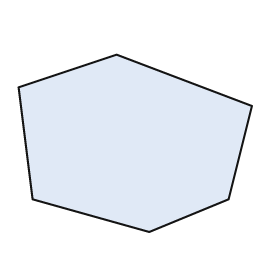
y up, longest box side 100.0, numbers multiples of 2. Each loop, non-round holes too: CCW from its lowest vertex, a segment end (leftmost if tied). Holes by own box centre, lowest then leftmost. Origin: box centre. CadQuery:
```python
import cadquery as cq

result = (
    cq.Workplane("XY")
    .moveTo(6.0, -38.0)
    .lineTo(40.0, -24.0)
    .lineTo(50.0, 16.0)
    .lineTo(-8.0, 38.0)
    .lineTo(-50.0, 24.0)
    .lineTo(-44.0, -24.0)
    .close()
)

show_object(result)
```